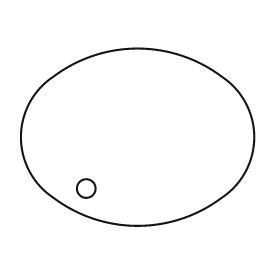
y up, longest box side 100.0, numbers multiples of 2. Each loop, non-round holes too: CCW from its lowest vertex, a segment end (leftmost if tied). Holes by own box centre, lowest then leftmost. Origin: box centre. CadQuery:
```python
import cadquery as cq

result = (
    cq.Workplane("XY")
    .moveTo(-36.0, -26.0)
    .threePointArc((0.0, -38.0), (36.0, -26.0))
    .threePointArc((50.0, 0.0), (36.0, 26.0))
    .threePointArc((0.0, 38.0), (-36.0, 26.0))
    .threePointArc((-50.0, 0.0), (-36.0, -26.0))
    .close()
    .moveTo(-22.0, -22.0)
    .circle(4.0)
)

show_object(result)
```